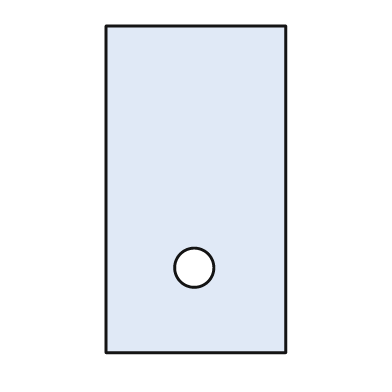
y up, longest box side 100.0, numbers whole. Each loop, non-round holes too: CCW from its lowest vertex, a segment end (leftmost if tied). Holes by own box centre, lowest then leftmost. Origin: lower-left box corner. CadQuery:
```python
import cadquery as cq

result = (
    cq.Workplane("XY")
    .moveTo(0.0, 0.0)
    .lineTo(55.0, 0.0)
    .lineTo(55.0, 100.0)
    .lineTo(0.0, 100.0)
    .close()
    .moveTo(27.0, 26.0)
    .circle(6.0)
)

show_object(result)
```